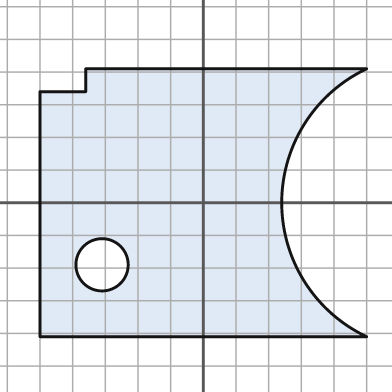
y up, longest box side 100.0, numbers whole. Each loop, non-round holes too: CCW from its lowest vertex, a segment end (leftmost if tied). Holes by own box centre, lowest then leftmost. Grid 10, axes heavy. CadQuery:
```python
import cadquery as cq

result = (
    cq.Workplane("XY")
    .moveTo(-50.0, -41.0)
    .lineTo(50.0, -41.0)
    .threePointArc((24.0, 0.0), (50.0, 41.0))
    .lineTo(-36.0, 41.0)
    .lineTo(-36.0, 34.0)
    .lineTo(-50.0, 34.0)
    .close()
    .moveTo(-31.0, -19.0)
    .circle(8.0)
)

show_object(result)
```